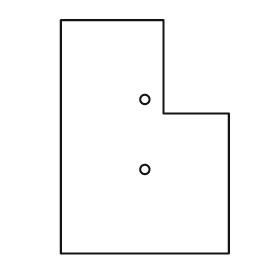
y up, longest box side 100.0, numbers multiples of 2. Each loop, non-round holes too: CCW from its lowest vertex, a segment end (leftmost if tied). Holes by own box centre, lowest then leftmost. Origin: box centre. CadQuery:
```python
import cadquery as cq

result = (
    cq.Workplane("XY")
    .moveTo(-36.0, -50.0)
    .lineTo(36.0, -50.0)
    .lineTo(36.0, 10.0)
    .lineTo(8.0, 10.0)
    .lineTo(8.0, 50.0)
    .lineTo(-36.0, 50.0)
    .close()
    .moveTo(0.0, -14.0)
    .circle(2.0)
    .moveTo(0.0, 16.0)
    .circle(2.0)
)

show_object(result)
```